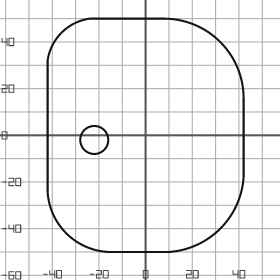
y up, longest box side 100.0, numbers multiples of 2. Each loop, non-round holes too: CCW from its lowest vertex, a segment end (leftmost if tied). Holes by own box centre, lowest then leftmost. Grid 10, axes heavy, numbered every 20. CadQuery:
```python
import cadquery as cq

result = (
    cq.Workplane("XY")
    .moveTo(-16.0, -50.0)
    .lineTo(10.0, -50.0)
    .threePointArc((32.0, -40.0), (42.0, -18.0))
    .lineTo(42.0, 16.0)
    .threePointArc((32.0, 40.0), (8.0, 50.0))
    .lineTo(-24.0, 50.0)
    .threePointArc((-36.0, 44.0), (-42.0, 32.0))
    .lineTo(-42.0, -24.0)
    .threePointArc((-34.0, -42.0), (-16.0, -50.0))
    .close()
    .moveTo(-22.0, -2.0)
    .circle(6.0)
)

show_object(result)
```